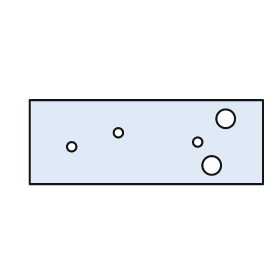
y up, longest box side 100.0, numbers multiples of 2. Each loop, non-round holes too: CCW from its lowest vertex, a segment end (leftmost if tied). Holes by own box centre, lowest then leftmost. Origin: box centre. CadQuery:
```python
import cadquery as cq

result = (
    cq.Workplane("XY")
    .moveTo(-50.0, -18.0)
    .lineTo(50.0, -18.0)
    .lineTo(50.0, 18.0)
    .lineTo(-50.0, 18.0)
    .close()
    .moveTo(28.0, -10.0)
    .circle(4.0)
    .moveTo(-32.0, -2.0)
    .circle(2.0)
    .moveTo(22.0, 0.0)
    .circle(2.0)
    .moveTo(-12.0, 4.0)
    .circle(2.0)
    .moveTo(34.0, 10.0)
    .circle(4.0)
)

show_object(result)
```